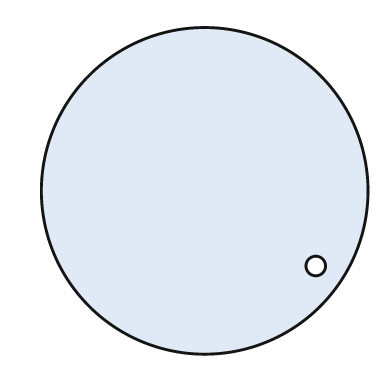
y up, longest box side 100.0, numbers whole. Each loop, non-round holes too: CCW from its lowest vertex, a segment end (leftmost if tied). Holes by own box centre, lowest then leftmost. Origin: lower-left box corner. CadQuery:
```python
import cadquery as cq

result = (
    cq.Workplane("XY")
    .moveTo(50.0, 50.0)
    .circle(50.0)
    .moveTo(84.0, 27.0)
    .circle(3.0)
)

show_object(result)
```